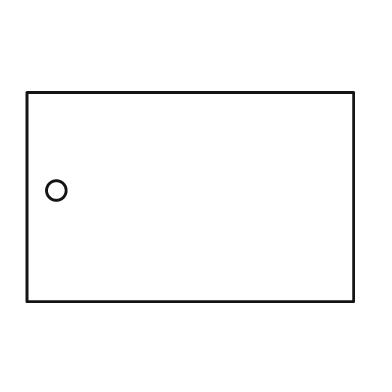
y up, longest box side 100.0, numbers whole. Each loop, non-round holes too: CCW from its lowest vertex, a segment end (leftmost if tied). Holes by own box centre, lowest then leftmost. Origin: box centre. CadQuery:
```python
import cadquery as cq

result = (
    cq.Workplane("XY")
    .moveTo(-50.0, -32.0)
    .lineTo(50.0, -32.0)
    .lineTo(50.0, 32.0)
    .lineTo(-50.0, 32.0)
    .close()
    .moveTo(-41.0, 2.0)
    .circle(3.0)
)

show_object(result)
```